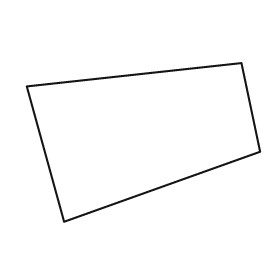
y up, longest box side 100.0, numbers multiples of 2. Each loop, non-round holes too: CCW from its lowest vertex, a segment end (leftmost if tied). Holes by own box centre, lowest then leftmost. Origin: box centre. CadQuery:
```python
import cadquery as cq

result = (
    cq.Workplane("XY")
    .moveTo(-34.0, -34.0)
    .lineTo(50.0, -4.0)
    .lineTo(42.0, 34.0)
    .lineTo(-50.0, 24.0)
    .close()
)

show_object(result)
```